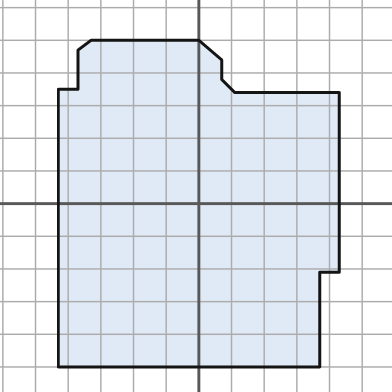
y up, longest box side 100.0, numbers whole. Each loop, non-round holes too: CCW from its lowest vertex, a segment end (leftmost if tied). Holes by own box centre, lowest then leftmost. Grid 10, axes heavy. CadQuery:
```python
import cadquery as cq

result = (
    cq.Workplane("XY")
    .moveTo(-43.0, -50.0)
    .lineTo(37.0, -50.0)
    .lineTo(37.0, -21.0)
    .lineTo(43.0, -21.0)
    .lineTo(43.0, 34.0)
    .lineTo(11.0, 34.0)
    .lineTo(7.0, 38.0)
    .lineTo(7.0, 44.0)
    .lineTo(0.0, 50.0)
    .lineTo(-33.0, 50.0)
    .lineTo(-37.0, 47.0)
    .lineTo(-37.0, 35.0)
    .lineTo(-43.0, 35.0)
    .close()
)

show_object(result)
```